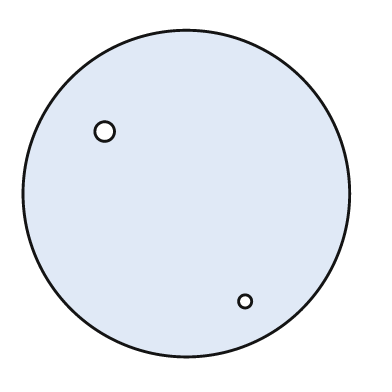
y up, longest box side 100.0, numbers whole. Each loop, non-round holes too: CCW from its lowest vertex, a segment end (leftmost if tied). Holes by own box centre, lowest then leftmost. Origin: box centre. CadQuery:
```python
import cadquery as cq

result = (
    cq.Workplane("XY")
    .moveTo(0.0, 0.0)
    .circle(50.0)
    .moveTo(18.0, -33.0)
    .circle(2.0)
    .moveTo(-25.0, 19.0)
    .circle(3.0)
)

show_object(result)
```